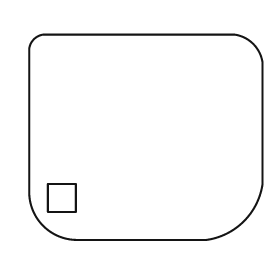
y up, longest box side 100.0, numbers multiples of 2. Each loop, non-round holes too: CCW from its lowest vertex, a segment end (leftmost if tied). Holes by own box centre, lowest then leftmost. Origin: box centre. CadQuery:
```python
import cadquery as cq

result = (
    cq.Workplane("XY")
    .moveTo(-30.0, -44.0)
    .lineTo(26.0, -44.0)
    .threePointArc((42.0, -36.0), (50.0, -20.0))
    .lineTo(50.0, 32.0)
    .threePointArc((46.0, 40.0), (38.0, 44.0))
    .lineTo(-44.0, 44.0)
    .threePointArc((-48.0, 42.0), (-50.0, 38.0))
    .lineTo(-50.0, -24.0)
    .threePointArc((-44.0, -38.0), (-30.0, -44.0))
    .close()
    .moveTo(-42.0, -32.0)
    .lineTo(-30.0, -32.0)
    .lineTo(-30.0, -20.0)
    .lineTo(-42.0, -20.0)
    .close()
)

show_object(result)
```